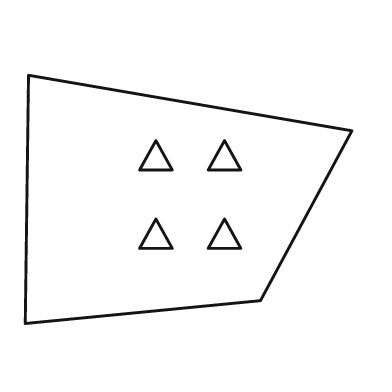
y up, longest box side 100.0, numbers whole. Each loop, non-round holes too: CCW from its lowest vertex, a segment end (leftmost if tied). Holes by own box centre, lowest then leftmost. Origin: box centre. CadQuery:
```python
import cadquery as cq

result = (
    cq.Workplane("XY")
    .moveTo(-50.0, -38.0)
    .lineTo(22.0, -31.0)
    .lineTo(50.0, 21.0)
    .lineTo(-49.0, 38.0)
    .close()
    .moveTo(-15.0, -15.0)
    .lineTo(-5.0, -15.0)
    .lineTo(-10.0, -6.0)
    .close()
    .moveTo(6.0, -15.0)
    .lineTo(16.0, -15.0)
    .lineTo(11.0, -6.0)
    .close()
    .moveTo(-15.0, 9.0)
    .lineTo(-5.0, 9.0)
    .lineTo(-10.0, 18.0)
    .close()
    .moveTo(6.0, 9.0)
    .lineTo(16.0, 9.0)
    .lineTo(11.0, 18.0)
    .close()
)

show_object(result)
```